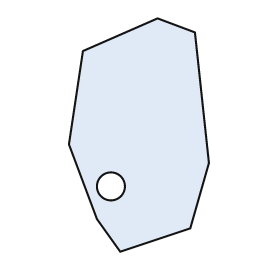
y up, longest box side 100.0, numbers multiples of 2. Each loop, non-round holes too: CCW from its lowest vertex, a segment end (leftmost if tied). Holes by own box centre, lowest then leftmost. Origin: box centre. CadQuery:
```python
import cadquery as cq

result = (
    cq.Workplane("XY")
    .moveTo(-8.0, -50.0)
    .lineTo(22.0, -40.0)
    .lineTo(30.0, -12.0)
    .lineTo(24.0, 44.0)
    .lineTo(8.0, 50.0)
    .lineTo(-24.0, 36.0)
    .lineTo(-30.0, -4.0)
    .lineTo(-18.0, -36.0)
    .close()
    .moveTo(-12.0, -22.0)
    .circle(6.0)
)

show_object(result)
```